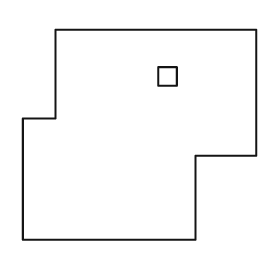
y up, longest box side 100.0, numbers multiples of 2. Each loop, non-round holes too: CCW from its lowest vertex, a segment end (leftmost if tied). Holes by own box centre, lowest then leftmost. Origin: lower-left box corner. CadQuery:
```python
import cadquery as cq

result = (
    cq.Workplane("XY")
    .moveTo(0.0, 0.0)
    .lineTo(74.0, 0.0)
    .lineTo(74.0, 36.0)
    .lineTo(100.0, 36.0)
    .lineTo(100.0, 90.0)
    .lineTo(14.0, 90.0)
    .lineTo(14.0, 52.0)
    .lineTo(0.0, 52.0)
    .close()
    .moveTo(58.0, 66.0)
    .lineTo(66.0, 66.0)
    .lineTo(66.0, 74.0)
    .lineTo(58.0, 74.0)
    .close()
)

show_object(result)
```